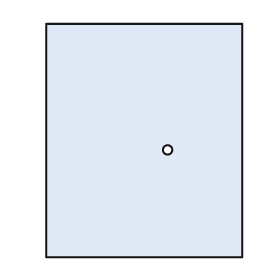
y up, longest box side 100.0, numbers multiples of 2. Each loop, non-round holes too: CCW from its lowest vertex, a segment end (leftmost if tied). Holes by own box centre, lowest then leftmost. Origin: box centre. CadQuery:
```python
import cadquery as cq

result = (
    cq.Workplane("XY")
    .moveTo(-42.0, -50.0)
    .lineTo(42.0, -50.0)
    .lineTo(42.0, 50.0)
    .lineTo(-42.0, 50.0)
    .close()
    .moveTo(10.0, -4.0)
    .circle(2.0)
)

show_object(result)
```